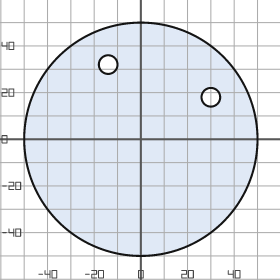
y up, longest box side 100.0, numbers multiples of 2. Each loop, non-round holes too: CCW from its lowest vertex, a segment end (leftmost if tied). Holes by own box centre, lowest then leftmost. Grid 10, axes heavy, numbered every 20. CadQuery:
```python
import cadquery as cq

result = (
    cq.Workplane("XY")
    .moveTo(0.0, 0.0)
    .circle(50.0)
    .moveTo(30.0, 18.0)
    .circle(4.0)
    .moveTo(-14.0, 32.0)
    .circle(4.0)
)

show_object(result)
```